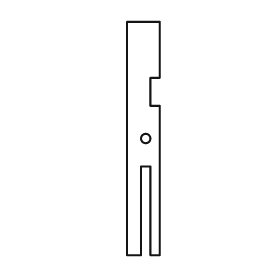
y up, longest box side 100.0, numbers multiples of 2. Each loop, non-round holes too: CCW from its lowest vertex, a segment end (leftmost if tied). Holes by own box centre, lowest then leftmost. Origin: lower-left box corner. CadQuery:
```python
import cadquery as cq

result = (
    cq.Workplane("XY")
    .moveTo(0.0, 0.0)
    .lineTo(6.0, 0.0)
    .lineTo(6.0, 38.0)
    .lineTo(10.0, 38.0)
    .lineTo(10.0, 0.0)
    .lineTo(14.0, 0.0)
    .lineTo(14.0, 64.0)
    .lineTo(10.0, 64.0)
    .lineTo(10.0, 76.0)
    .lineTo(14.0, 76.0)
    .lineTo(14.0, 100.0)
    .lineTo(0.0, 100.0)
    .close()
    .moveTo(8.0, 50.0)
    .circle(2.0)
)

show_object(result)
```